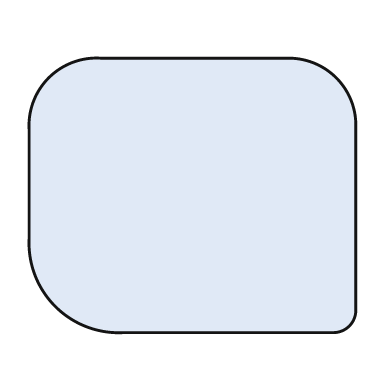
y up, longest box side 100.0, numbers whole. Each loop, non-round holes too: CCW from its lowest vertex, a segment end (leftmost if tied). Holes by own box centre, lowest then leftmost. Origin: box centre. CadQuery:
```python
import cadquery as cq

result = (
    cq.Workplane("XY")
    .moveTo(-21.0, -42.0)
    .lineTo(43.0, -42.0)
    .threePointArc((48.0, -40.0), (50.0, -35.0))
    .lineTo(50.0, 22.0)
    .threePointArc((44.0, 36.0), (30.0, 42.0))
    .lineTo(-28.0, 42.0)
    .threePointArc((-44.0, 36.0), (-50.0, 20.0))
    .lineTo(-50.0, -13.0)
    .threePointArc((-42.0, -34.0), (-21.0, -42.0))
    .close()
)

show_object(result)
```